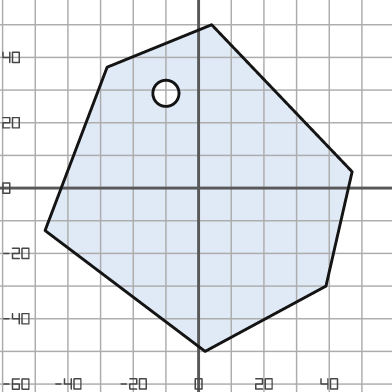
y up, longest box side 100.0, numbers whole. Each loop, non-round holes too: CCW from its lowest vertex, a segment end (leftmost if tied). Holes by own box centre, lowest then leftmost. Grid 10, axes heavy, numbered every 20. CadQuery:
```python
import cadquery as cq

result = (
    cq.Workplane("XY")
    .moveTo(2.0, -50.0)
    .lineTo(39.0, -30.0)
    .lineTo(47.0, 5.0)
    .lineTo(4.0, 50.0)
    .lineTo(-28.0, 37.0)
    .lineTo(-47.0, -13.0)
    .close()
    .moveTo(-10.0, 29.0)
    .circle(4.0)
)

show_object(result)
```